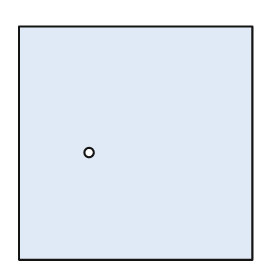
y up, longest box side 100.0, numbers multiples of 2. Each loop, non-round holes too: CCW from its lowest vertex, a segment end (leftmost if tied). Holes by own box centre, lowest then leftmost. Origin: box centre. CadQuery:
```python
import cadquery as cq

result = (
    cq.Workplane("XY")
    .moveTo(-50.0, -50.0)
    .lineTo(50.0, -50.0)
    .lineTo(50.0, 50.0)
    .lineTo(-50.0, 50.0)
    .close()
    .moveTo(-20.0, -4.0)
    .circle(2.0)
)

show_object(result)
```